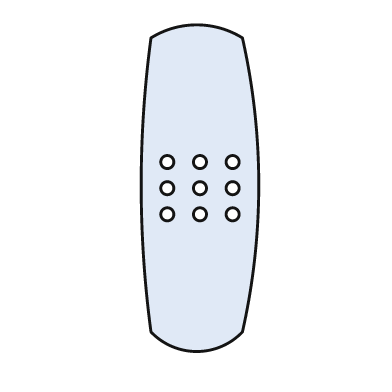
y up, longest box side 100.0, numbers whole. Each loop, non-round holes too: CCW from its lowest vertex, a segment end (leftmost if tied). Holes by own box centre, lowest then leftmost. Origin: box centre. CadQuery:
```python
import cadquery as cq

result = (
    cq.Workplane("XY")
    .moveTo(-15.0, -44.0)
    .threePointArc((-1.0, -50.0), (13.0, -44.0))
    .threePointArc((18.0, 1.0), (13.0, 46.0))
    .threePointArc((-1.0, 50.0), (-15.0, 46.0))
    .threePointArc((-18.0, 1.0), (-15.0, -44.0))
    .close()
    .moveTo(-10.0, -8.0)
    .circle(2.0)
    .moveTo(0.0, -8.0)
    .circle(2.0)
    .moveTo(10.0, -8.0)
    .circle(2.0)
    .moveTo(-10.0, 0.0)
    .circle(2.0)
    .moveTo(0.0, 0.0)
    .circle(2.0)
    .moveTo(10.0, 0.0)
    .circle(2.0)
    .moveTo(-10.0, 8.0)
    .circle(2.0)
    .moveTo(0.0, 8.0)
    .circle(2.0)
    .moveTo(10.0, 8.0)
    .circle(2.0)
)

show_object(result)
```